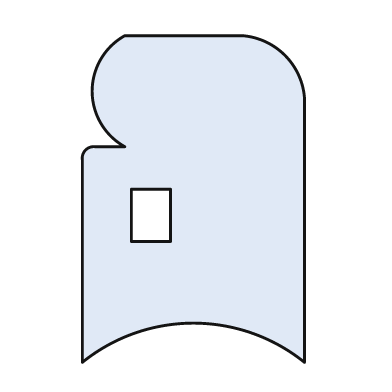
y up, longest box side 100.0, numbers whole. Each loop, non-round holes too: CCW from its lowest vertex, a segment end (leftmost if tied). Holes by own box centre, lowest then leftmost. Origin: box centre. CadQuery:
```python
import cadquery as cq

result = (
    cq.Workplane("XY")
    .moveTo(-34.0, -50.0)
    .threePointArc((0.0, -38.0), (34.0, -50.0))
    .lineTo(34.0, 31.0)
    .threePointArc((28.0, 44.0), (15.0, 50.0))
    .lineTo(-21.0, 50.0)
    .threePointArc((-31.0, 33.0), (-21.0, 16.0))
    .lineTo(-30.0, 16.0)
    .threePointArc((-33.0, 15.0), (-34.0, 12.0))
    .close()
    .moveTo(-19.0, -13.0)
    .lineTo(-7.0, -13.0)
    .lineTo(-7.0, 3.0)
    .lineTo(-19.0, 3.0)
    .close()
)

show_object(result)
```